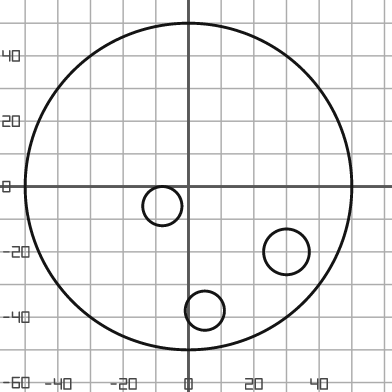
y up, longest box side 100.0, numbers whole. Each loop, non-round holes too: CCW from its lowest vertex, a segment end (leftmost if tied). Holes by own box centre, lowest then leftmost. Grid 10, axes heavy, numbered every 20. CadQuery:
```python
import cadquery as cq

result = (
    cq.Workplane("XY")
    .moveTo(0.0, 0.0)
    .circle(50.0)
    .moveTo(5.0, -38.0)
    .circle(6.0)
    .moveTo(30.0, -20.0)
    .circle(7.0)
    .moveTo(-8.0, -6.0)
    .circle(6.0)
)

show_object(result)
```